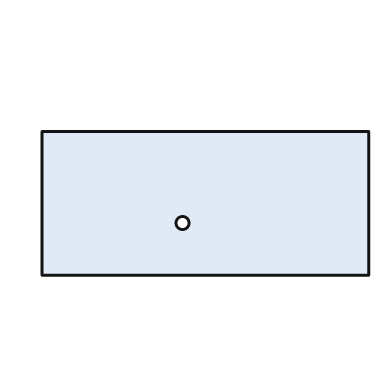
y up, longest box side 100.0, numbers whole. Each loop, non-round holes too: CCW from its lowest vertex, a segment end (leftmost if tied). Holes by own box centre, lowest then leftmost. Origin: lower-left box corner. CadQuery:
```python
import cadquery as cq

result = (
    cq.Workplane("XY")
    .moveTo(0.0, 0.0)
    .lineTo(100.0, 0.0)
    .lineTo(100.0, 44.0)
    .lineTo(0.0, 44.0)
    .close()
    .moveTo(43.0, 16.0)
    .circle(2.0)
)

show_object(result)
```